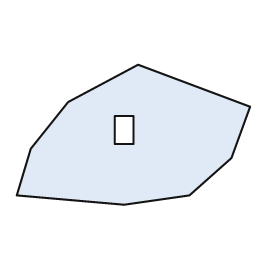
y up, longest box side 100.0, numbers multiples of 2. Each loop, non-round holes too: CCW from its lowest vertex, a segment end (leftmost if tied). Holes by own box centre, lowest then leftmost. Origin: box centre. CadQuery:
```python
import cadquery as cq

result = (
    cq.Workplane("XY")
    .moveTo(-4.0, -30.0)
    .lineTo(24.0, -26.0)
    .lineTo(42.0, -10.0)
    .lineTo(50.0, 12.0)
    .lineTo(2.0, 30.0)
    .lineTo(-28.0, 14.0)
    .lineTo(-44.0, -6.0)
    .lineTo(-50.0, -26.0)
    .close()
    .moveTo(-8.0, -4.0)
    .lineTo(0.0, -4.0)
    .lineTo(0.0, 8.0)
    .lineTo(-8.0, 8.0)
    .close()
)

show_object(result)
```